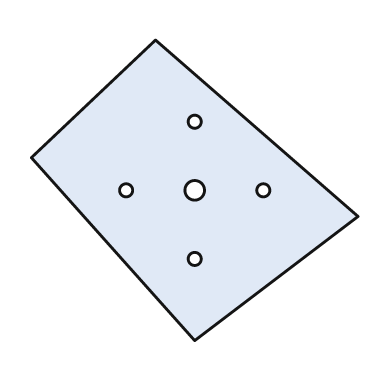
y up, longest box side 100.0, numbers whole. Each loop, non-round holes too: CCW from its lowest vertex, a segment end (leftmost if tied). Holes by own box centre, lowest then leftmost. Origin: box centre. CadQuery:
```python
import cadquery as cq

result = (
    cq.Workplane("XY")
    .moveTo(0.0, -46.0)
    .lineTo(50.0, -8.0)
    .lineTo(-12.0, 46.0)
    .lineTo(-50.0, 10.0)
    .close()
    .moveTo(0.0, -21.0)
    .circle(2.0)
    .moveTo(-21.0, 0.0)
    .circle(2.0)
    .moveTo(0.0, 0.0)
    .circle(3.0)
    .moveTo(21.0, 0.0)
    .circle(2.0)
    .moveTo(0.0, 21.0)
    .circle(2.0)
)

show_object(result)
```